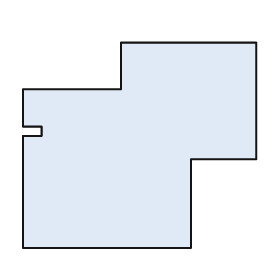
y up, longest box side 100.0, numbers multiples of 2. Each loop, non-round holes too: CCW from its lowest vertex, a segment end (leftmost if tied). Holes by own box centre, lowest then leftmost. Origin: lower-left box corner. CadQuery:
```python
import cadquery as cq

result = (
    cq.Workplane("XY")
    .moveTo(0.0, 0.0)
    .lineTo(72.0, 0.0)
    .lineTo(72.0, 38.0)
    .lineTo(100.0, 38.0)
    .lineTo(100.0, 88.0)
    .lineTo(42.0, 88.0)
    .lineTo(42.0, 68.0)
    .lineTo(0.0, 68.0)
    .lineTo(0.0, 52.0)
    .lineTo(8.0, 52.0)
    .lineTo(8.0, 48.0)
    .lineTo(0.0, 48.0)
    .close()
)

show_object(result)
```